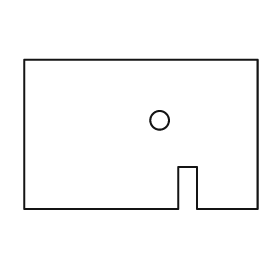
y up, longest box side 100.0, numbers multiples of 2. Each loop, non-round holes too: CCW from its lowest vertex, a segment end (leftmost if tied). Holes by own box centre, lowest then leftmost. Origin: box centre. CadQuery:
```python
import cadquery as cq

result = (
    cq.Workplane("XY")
    .moveTo(-50.0, -32.0)
    .lineTo(16.0, -32.0)
    .lineTo(16.0, -14.0)
    .lineTo(24.0, -14.0)
    .lineTo(24.0, -32.0)
    .lineTo(50.0, -32.0)
    .lineTo(50.0, 32.0)
    .lineTo(-50.0, 32.0)
    .close()
    .moveTo(8.0, 6.0)
    .circle(4.0)
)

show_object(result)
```